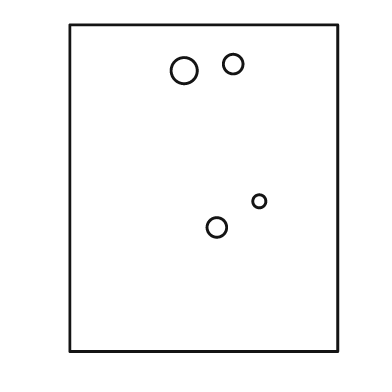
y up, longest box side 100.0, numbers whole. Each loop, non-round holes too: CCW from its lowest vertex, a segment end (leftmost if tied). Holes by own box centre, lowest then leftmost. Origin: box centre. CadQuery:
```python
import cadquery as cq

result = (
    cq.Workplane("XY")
    .moveTo(-41.0, -50.0)
    .lineTo(41.0, -50.0)
    .lineTo(41.0, 50.0)
    .lineTo(-41.0, 50.0)
    .close()
    .moveTo(4.0, -12.0)
    .circle(3.0)
    .moveTo(17.0, -4.0)
    .circle(2.0)
    .moveTo(-6.0, 36.0)
    .circle(4.0)
    .moveTo(9.0, 38.0)
    .circle(3.0)
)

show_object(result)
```